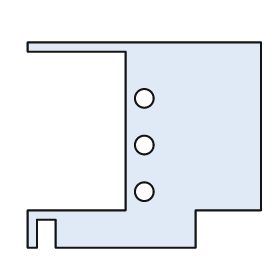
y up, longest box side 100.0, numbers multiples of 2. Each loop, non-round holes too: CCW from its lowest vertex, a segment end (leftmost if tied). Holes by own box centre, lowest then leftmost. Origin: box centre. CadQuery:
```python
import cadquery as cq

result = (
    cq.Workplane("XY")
    .moveTo(-50.0, -44.0)
    .lineTo(-46.0, -44.0)
    .lineTo(-46.0, -32.0)
    .lineTo(-38.0, -32.0)
    .lineTo(-38.0, -44.0)
    .lineTo(22.0, -44.0)
    .lineTo(22.0, -28.0)
    .lineTo(50.0, -28.0)
    .lineTo(50.0, 44.0)
    .lineTo(-50.0, 44.0)
    .lineTo(-50.0, 40.0)
    .lineTo(-8.0, 40.0)
    .lineTo(-8.0, -28.0)
    .lineTo(-50.0, -28.0)
    .close()
    .moveTo(0.0, -20.0)
    .circle(4.0)
    .moveTo(0.0, 0.0)
    .circle(4.0)
    .moveTo(0.0, 20.0)
    .circle(4.0)
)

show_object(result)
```